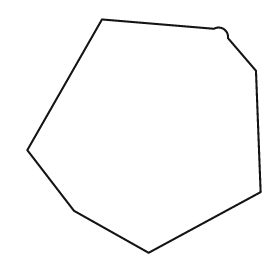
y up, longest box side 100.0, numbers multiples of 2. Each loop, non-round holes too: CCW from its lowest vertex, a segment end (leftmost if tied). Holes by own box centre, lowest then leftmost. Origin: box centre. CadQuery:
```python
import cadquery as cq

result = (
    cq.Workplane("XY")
    .moveTo(2.0, -50.0)
    .lineTo(50.0, -24.0)
    .lineTo(48.0, 28.0)
    .lineTo(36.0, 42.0)
    .threePointArc((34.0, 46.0), (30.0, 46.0))
    .lineTo(-18.0, 50.0)
    .lineTo(-50.0, -6.0)
    .lineTo(-30.0, -32.0)
    .close()
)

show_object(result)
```